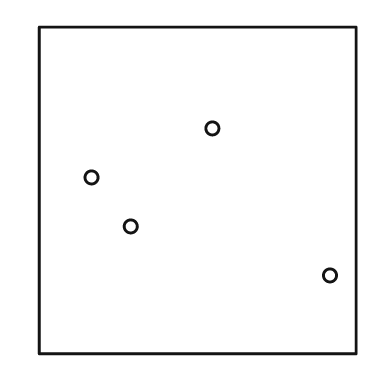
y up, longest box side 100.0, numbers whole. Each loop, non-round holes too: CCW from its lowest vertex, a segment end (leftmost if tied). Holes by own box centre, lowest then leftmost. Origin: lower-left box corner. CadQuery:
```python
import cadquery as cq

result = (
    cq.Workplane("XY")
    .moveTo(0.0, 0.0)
    .lineTo(97.0, 0.0)
    .lineTo(97.0, 100.0)
    .lineTo(0.0, 100.0)
    .close()
    .moveTo(89.0, 24.0)
    .circle(2.0)
    .moveTo(28.0, 39.0)
    .circle(2.0)
    .moveTo(16.0, 54.0)
    .circle(2.0)
    .moveTo(53.0, 69.0)
    .circle(2.0)
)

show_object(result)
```